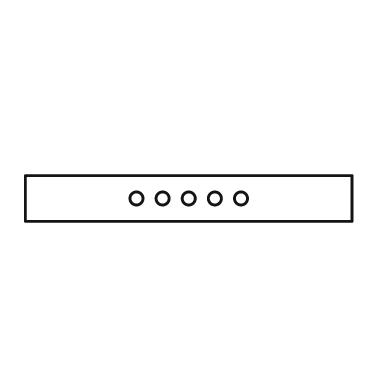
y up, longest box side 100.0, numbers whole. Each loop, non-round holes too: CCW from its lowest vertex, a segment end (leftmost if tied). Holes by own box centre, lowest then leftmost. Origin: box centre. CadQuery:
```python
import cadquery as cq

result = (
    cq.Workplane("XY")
    .moveTo(-50.0, -7.0)
    .lineTo(50.0, -7.0)
    .lineTo(50.0, 7.0)
    .lineTo(-50.0, 7.0)
    .close()
    .moveTo(-16.0, 0.0)
    .circle(2.0)
    .moveTo(-8.0, 0.0)
    .circle(2.0)
    .moveTo(0.0, 0.0)
    .circle(2.0)
    .moveTo(8.0, 0.0)
    .circle(2.0)
    .moveTo(16.0, 0.0)
    .circle(2.0)
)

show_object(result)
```